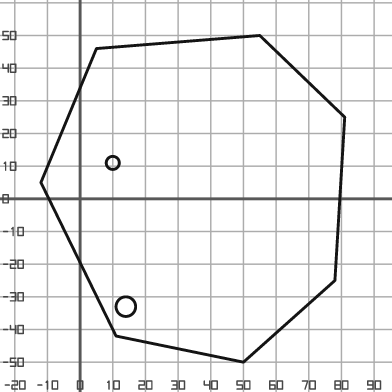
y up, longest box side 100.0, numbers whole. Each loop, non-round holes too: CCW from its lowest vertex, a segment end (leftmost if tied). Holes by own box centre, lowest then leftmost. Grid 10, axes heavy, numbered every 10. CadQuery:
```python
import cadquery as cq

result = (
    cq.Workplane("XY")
    .moveTo(50.0, -50.0)
    .lineTo(78.0, -25.0)
    .lineTo(81.0, 25.0)
    .lineTo(55.0, 50.0)
    .lineTo(5.0, 46.0)
    .lineTo(-12.0, 5.0)
    .lineTo(11.0, -42.0)
    .close()
    .moveTo(14.0, -33.0)
    .circle(3.0)
    .moveTo(10.0, 11.0)
    .circle(2.0)
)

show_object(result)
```